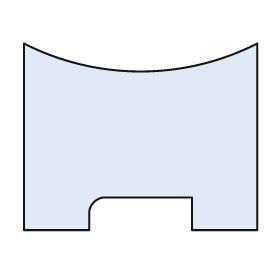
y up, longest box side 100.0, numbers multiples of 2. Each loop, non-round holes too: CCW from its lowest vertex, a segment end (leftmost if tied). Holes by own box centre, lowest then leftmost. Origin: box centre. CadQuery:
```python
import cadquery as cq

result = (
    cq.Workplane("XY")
    .moveTo(-50.0, -40.0)
    .lineTo(-22.0, -40.0)
    .lineTo(-22.0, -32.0)
    .threePointArc((-20.0, -28.0), (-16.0, -26.0))
    .lineTo(22.0, -26.0)
    .lineTo(22.0, -40.0)
    .lineTo(50.0, -40.0)
    .lineTo(50.0, 40.0)
    .threePointArc((0.0, 28.0), (-50.0, 40.0))
    .close()
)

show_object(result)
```